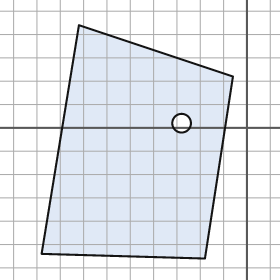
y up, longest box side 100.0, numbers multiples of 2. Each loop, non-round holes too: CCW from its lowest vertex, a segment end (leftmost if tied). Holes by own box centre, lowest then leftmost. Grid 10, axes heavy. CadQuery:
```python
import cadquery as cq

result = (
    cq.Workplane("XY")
    .moveTo(-18.0, -56.0)
    .lineTo(-6.0, 22.0)
    .lineTo(-72.0, 44.0)
    .lineTo(-88.0, -54.0)
    .close()
    .moveTo(-28.0, 2.0)
    .circle(4.0)
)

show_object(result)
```